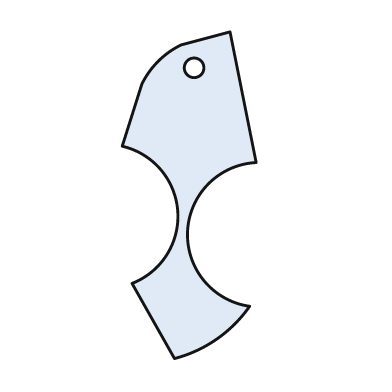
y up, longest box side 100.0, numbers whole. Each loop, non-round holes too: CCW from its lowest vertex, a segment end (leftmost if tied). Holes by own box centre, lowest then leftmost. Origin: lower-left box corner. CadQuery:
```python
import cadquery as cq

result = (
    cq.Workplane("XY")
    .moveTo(16.0, 0.0)
    .threePointArc((29.0, 6.0), (39.0, 16.0))
    .threePointArc((20.0, 39.0), (41.0, 60.0))
    .lineTo(33.0, 100.0)
    .lineTo(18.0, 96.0)
    .threePointArc((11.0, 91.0), (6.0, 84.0))
    .lineTo(0.0, 65.0)
    .threePointArc((17.0, 45.0), (3.0, 23.0))
    .close()
    .moveTo(22.0, 89.0)
    .circle(3.0)
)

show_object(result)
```